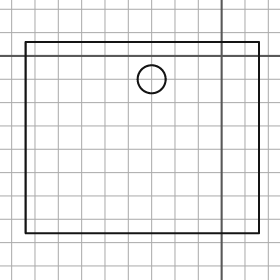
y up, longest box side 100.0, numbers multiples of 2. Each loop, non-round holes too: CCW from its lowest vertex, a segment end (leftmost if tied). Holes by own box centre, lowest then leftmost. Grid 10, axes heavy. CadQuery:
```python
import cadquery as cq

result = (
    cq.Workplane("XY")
    .moveTo(-84.0, -76.0)
    .lineTo(16.0, -76.0)
    .lineTo(16.0, 6.0)
    .lineTo(-84.0, 6.0)
    .close()
    .moveTo(-30.0, -10.0)
    .circle(6.0)
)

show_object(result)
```